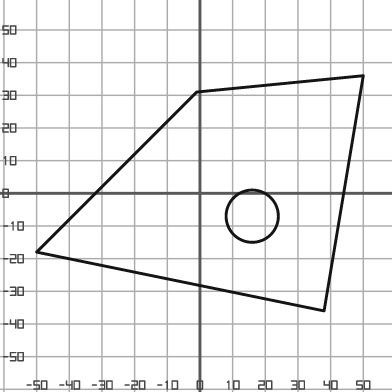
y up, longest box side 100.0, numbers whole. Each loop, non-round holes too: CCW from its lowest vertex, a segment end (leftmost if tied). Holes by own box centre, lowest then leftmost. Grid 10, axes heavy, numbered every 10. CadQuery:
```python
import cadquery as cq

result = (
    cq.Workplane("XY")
    .moveTo(38.0, -36.0)
    .lineTo(50.0, 36.0)
    .lineTo(-1.0, 31.0)
    .lineTo(-50.0, -18.0)
    .close()
    .moveTo(16.0, -7.0)
    .circle(8.0)
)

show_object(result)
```